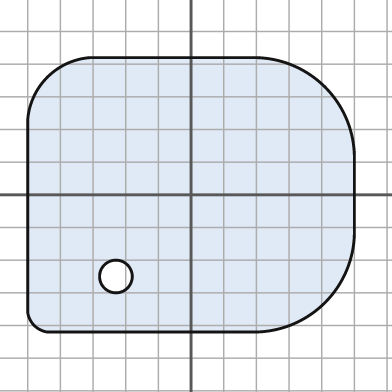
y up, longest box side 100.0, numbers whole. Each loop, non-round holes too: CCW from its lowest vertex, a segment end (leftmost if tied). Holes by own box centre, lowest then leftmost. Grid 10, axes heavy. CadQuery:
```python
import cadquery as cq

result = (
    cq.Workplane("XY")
    .moveTo(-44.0, -42.0)
    .lineTo(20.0, -42.0)
    .threePointArc((41.0, -33.0), (50.0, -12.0))
    .lineTo(50.0, 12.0)
    .threePointArc((41.0, 33.0), (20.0, 42.0))
    .lineTo(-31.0, 42.0)
    .threePointArc((-44.0, 36.0), (-50.0, 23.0))
    .lineTo(-50.0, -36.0)
    .threePointArc((-48.0, -40.0), (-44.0, -42.0))
    .close()
    .moveTo(-23.0, -25.0)
    .circle(5.0)
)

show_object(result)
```